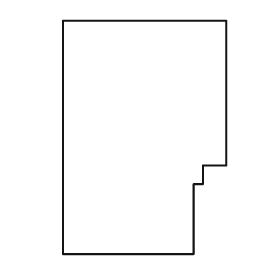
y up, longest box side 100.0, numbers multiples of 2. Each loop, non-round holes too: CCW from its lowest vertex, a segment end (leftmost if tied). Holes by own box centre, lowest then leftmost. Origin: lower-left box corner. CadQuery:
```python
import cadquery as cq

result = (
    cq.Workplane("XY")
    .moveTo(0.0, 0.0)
    .lineTo(56.0, 0.0)
    .lineTo(56.0, 30.0)
    .lineTo(60.0, 30.0)
    .lineTo(60.0, 38.0)
    .lineTo(70.0, 38.0)
    .lineTo(70.0, 100.0)
    .lineTo(0.0, 100.0)
    .close()
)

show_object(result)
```